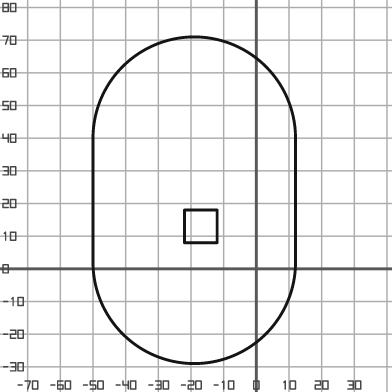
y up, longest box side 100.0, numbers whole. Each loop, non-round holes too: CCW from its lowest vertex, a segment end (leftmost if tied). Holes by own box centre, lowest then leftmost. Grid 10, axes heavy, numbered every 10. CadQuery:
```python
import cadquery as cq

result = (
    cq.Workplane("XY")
    .moveTo(-50.0, 2.0)
    .threePointArc((-19.0, -29.0), (12.0, 2.0))
    .lineTo(12.0, 40.0)
    .threePointArc((-19.0, 71.0), (-50.0, 40.0))
    .close()
    .moveTo(-22.0, 8.0)
    .lineTo(-12.0, 8.0)
    .lineTo(-12.0, 18.0)
    .lineTo(-22.0, 18.0)
    .close()
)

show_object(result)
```